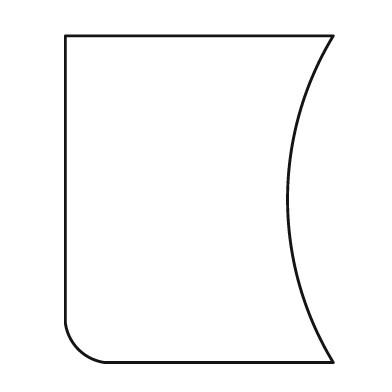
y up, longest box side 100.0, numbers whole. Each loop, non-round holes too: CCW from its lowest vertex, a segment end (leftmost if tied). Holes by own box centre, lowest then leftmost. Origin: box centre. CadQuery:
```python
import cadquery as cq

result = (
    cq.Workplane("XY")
    .moveTo(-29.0, -50.0)
    .lineTo(41.0, -50.0)
    .threePointArc((27.0, 0.0), (41.0, 50.0))
    .lineTo(-41.0, 50.0)
    .lineTo(-41.0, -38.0)
    .threePointArc((-37.0, -46.0), (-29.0, -50.0))
    .close()
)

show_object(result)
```